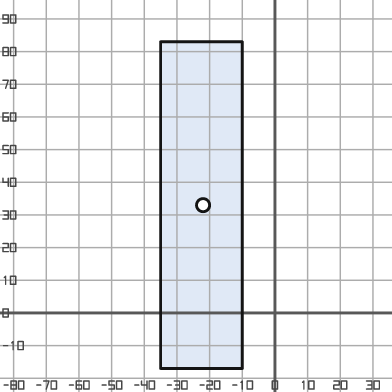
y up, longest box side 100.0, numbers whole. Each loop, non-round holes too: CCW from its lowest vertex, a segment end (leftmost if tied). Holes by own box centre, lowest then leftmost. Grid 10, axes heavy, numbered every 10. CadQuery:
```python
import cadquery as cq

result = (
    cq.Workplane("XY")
    .moveTo(-35.0, -17.0)
    .lineTo(-10.0, -17.0)
    .lineTo(-10.0, 83.0)
    .lineTo(-35.0, 83.0)
    .close()
    .moveTo(-22.0, 33.0)
    .circle(2.0)
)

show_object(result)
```